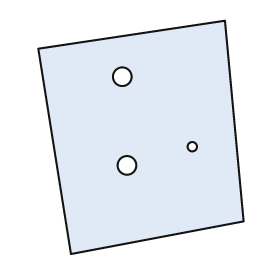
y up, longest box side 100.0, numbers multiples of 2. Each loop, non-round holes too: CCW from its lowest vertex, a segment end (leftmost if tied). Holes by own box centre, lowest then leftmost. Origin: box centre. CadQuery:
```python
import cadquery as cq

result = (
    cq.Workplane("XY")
    .moveTo(-30.0, -50.0)
    .lineTo(44.0, -36.0)
    .lineTo(36.0, 50.0)
    .lineTo(-44.0, 38.0)
    .close()
    .moveTo(-6.0, -12.0)
    .circle(4.0)
    .moveTo(22.0, -4.0)
    .circle(2.0)
    .moveTo(-8.0, 26.0)
    .circle(4.0)
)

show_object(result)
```